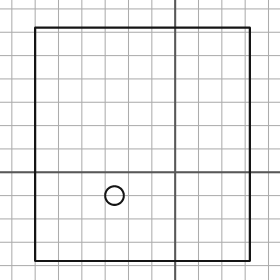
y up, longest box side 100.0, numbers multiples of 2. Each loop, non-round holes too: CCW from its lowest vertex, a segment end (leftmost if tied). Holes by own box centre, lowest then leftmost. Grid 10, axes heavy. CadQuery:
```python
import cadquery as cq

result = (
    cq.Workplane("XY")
    .moveTo(-60.0, -38.0)
    .lineTo(32.0, -38.0)
    .lineTo(32.0, 62.0)
    .lineTo(-60.0, 62.0)
    .close()
    .moveTo(-26.0, -10.0)
    .circle(4.0)
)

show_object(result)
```